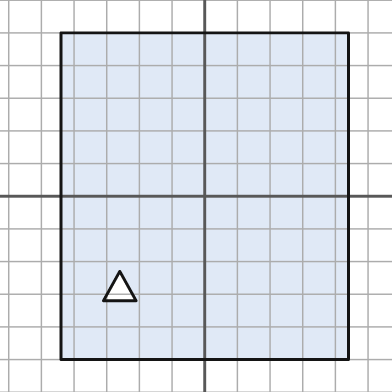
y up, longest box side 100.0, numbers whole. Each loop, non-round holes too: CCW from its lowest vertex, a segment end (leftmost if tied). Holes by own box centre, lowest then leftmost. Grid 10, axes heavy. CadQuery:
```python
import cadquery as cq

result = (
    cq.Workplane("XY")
    .moveTo(-44.0, -50.0)
    .lineTo(44.0, -50.0)
    .lineTo(44.0, 50.0)
    .lineTo(-44.0, 50.0)
    .close()
    .moveTo(-31.0, -32.0)
    .lineTo(-21.0, -32.0)
    .lineTo(-26.0, -23.0)
    .close()
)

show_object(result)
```